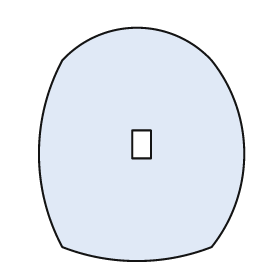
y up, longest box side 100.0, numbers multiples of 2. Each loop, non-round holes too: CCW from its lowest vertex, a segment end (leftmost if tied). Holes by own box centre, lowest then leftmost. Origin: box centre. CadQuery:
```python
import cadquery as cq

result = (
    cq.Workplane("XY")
    .moveTo(-34.0, -44.0)
    .threePointArc((-2.0, -50.0), (30.0, -44.0))
    .threePointArc((44.0, -4.0), (30.0, 36.0))
    .threePointArc((-2.0, 50.0), (-34.0, 36.0))
    .threePointArc((-44.0, -4.0), (-34.0, -44.0))
    .close()
    .moveTo(-4.0, -6.0)
    .lineTo(4.0, -6.0)
    .lineTo(4.0, 6.0)
    .lineTo(-4.0, 6.0)
    .close()
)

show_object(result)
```